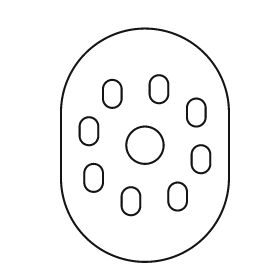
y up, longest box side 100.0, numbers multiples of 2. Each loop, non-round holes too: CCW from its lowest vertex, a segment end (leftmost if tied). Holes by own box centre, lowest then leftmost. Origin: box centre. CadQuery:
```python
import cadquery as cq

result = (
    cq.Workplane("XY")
    .moveTo(-36.0, -14.0)
    .threePointArc((0.0, -50.0), (36.0, -14.0))
    .lineTo(36.0, 14.0)
    .threePointArc((0.0, 50.0), (-36.0, 14.0))
    .close()
    .moveTo(-10.0, -26.0)
    .threePointArc((-6.0, -30.0), (-2.0, -26.0))
    .lineTo(-2.0, -22.0)
    .threePointArc((-6.0, -18.0), (-10.0, -22.0))
    .close()
    .moveTo(10.0, -24.0)
    .threePointArc((14.0, -28.0), (18.0, -24.0))
    .lineTo(18.0, -20.0)
    .threePointArc((14.0, -16.0), (10.0, -20.0))
    .close()
    .moveTo(-26.0, -16.0)
    .threePointArc((-22.0, -20.0), (-18.0, -16.0))
    .lineTo(-18.0, -12.0)
    .threePointArc((-22.0, -8.0), (-26.0, -12.0))
    .close()
    .moveTo(20.0, -8.0)
    .threePointArc((24.0, -12.0), (28.0, -8.0))
    .lineTo(28.0, -4.0)
    .threePointArc((24.0, 0.0), (20.0, -4.0))
    .close()
    .moveTo(0.0, 0.0)
    .circle(8.0)
    .moveTo(-28.0, 4.0)
    .threePointArc((-24.0, 0.0), (-20.0, 4.0))
    .lineTo(-20.0, 8.0)
    .threePointArc((-24.0, 12.0), (-28.0, 8.0))
    .close()
    .moveTo(18.0, 12.0)
    .threePointArc((22.0, 8.0), (26.0, 12.0))
    .lineTo(26.0, 16.0)
    .threePointArc((22.0, 20.0), (18.0, 16.0))
    .close()
    .moveTo(-18.0, 20.0)
    .threePointArc((-14.0, 16.0), (-10.0, 20.0))
    .lineTo(-10.0, 24.0)
    .threePointArc((-14.0, 28.0), (-18.0, 24.0))
    .close()
    .moveTo(2.0, 22.0)
    .threePointArc((6.0, 18.0), (10.0, 22.0))
    .lineTo(10.0, 26.0)
    .threePointArc((6.0, 30.0), (2.0, 26.0))
    .close()
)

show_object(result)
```